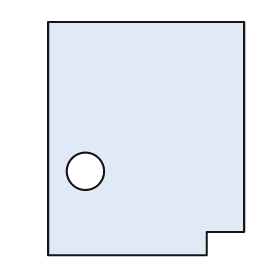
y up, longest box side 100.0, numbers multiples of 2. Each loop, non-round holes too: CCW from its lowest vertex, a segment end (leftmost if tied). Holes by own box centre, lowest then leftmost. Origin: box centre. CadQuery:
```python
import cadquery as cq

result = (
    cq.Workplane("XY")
    .moveTo(-42.0, -50.0)
    .lineTo(26.0, -50.0)
    .lineTo(26.0, -40.0)
    .lineTo(42.0, -40.0)
    .lineTo(42.0, 50.0)
    .lineTo(-42.0, 50.0)
    .close()
    .moveTo(-26.0, -14.0)
    .circle(8.0)
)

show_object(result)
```